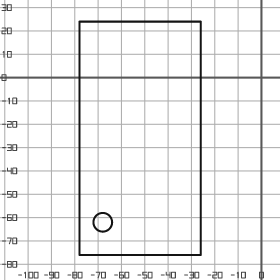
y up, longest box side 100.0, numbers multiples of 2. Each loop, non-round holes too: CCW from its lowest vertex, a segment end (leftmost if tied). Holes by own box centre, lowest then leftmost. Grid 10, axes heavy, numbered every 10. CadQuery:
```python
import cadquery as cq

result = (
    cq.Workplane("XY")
    .moveTo(-78.0, -76.0)
    .lineTo(-26.0, -76.0)
    .lineTo(-26.0, 24.0)
    .lineTo(-78.0, 24.0)
    .close()
    .moveTo(-68.0, -62.0)
    .circle(4.0)
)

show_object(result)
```